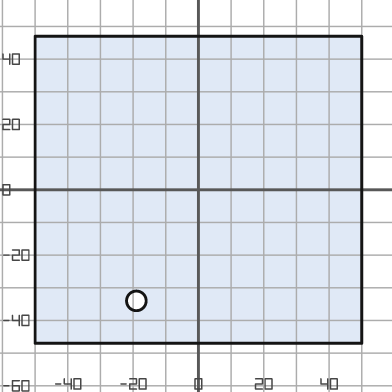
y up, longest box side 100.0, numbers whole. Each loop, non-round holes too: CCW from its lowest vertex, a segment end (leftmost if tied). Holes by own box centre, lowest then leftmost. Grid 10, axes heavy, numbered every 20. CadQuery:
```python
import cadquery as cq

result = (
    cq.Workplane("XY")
    .moveTo(-50.0, -47.0)
    .lineTo(50.0, -47.0)
    .lineTo(50.0, 47.0)
    .lineTo(-50.0, 47.0)
    .close()
    .moveTo(-19.0, -34.0)
    .circle(3.0)
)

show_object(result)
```